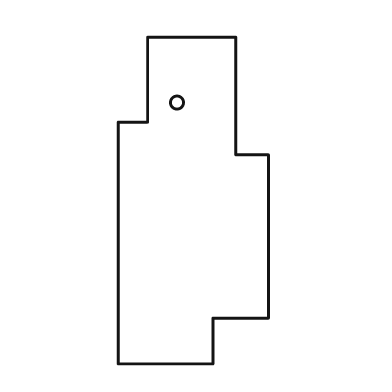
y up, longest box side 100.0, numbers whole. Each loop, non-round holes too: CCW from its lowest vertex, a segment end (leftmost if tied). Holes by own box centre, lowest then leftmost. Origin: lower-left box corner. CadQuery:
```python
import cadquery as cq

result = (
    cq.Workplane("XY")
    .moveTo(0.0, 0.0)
    .lineTo(29.0, 0.0)
    .lineTo(29.0, 14.0)
    .lineTo(46.0, 14.0)
    .lineTo(46.0, 64.0)
    .lineTo(36.0, 64.0)
    .lineTo(36.0, 100.0)
    .lineTo(9.0, 100.0)
    .lineTo(9.0, 74.0)
    .lineTo(0.0, 74.0)
    .close()
    .moveTo(18.0, 80.0)
    .circle(2.0)
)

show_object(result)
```